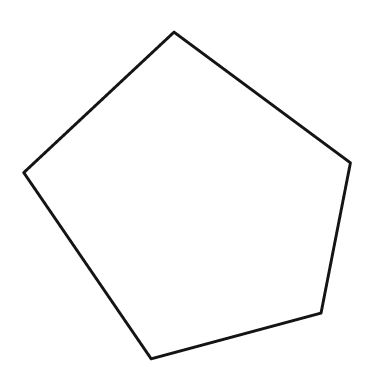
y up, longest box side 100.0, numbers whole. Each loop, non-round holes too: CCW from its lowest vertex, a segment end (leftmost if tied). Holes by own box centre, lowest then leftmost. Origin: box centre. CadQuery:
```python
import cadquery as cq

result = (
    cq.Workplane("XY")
    .moveTo(-11.0, -50.0)
    .lineTo(41.0, -36.0)
    .lineTo(50.0, 10.0)
    .lineTo(-4.0, 50.0)
    .lineTo(-50.0, 7.0)
    .close()
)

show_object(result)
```